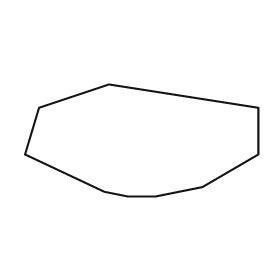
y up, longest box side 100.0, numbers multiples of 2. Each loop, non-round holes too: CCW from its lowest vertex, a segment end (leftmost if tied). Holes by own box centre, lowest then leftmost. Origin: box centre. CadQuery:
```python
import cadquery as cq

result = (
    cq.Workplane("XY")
    .moveTo(-6.0, -24.0)
    .lineTo(6.0, -24.0)
    .lineTo(26.0, -20.0)
    .lineTo(50.0, -6.0)
    .lineTo(50.0, 14.0)
    .lineTo(-14.0, 24.0)
    .lineTo(-44.0, 14.0)
    .lineTo(-50.0, -6.0)
    .lineTo(-16.0, -22.0)
    .close()
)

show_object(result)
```